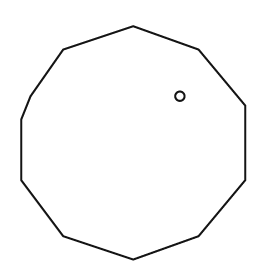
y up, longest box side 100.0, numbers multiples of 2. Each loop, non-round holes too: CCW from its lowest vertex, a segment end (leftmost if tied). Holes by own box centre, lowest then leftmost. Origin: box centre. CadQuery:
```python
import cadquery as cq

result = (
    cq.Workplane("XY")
    .moveTo(0.0, -50.0)
    .lineTo(28.0, -40.0)
    .lineTo(48.0, -16.0)
    .lineTo(48.0, 16.0)
    .lineTo(28.0, 40.0)
    .lineTo(0.0, 50.0)
    .lineTo(-30.0, 40.0)
    .lineTo(-44.0, 20.0)
    .lineTo(-48.0, 10.0)
    .lineTo(-48.0, -16.0)
    .lineTo(-30.0, -40.0)
    .close()
    .moveTo(20.0, 20.0)
    .circle(2.0)
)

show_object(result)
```